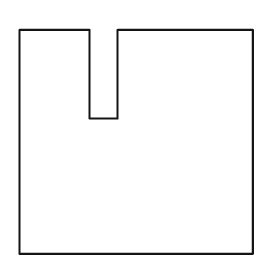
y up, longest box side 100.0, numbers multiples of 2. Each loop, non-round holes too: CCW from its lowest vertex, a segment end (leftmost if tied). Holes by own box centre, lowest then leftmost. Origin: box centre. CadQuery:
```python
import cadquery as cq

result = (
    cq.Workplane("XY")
    .moveTo(-50.0, -48.0)
    .lineTo(50.0, -48.0)
    .lineTo(50.0, 48.0)
    .lineTo(-8.0, 48.0)
    .lineTo(-8.0, 10.0)
    .lineTo(-20.0, 10.0)
    .lineTo(-20.0, 48.0)
    .lineTo(-50.0, 48.0)
    .close()
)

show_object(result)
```